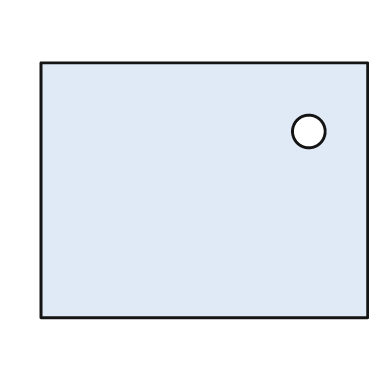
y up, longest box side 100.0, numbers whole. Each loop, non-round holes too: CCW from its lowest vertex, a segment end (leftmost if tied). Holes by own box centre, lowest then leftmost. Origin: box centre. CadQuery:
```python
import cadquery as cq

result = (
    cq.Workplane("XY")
    .moveTo(-50.0, -39.0)
    .lineTo(50.0, -39.0)
    .lineTo(50.0, 39.0)
    .lineTo(-50.0, 39.0)
    .close()
    .moveTo(32.0, 18.0)
    .circle(5.0)
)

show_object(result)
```